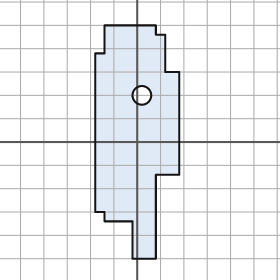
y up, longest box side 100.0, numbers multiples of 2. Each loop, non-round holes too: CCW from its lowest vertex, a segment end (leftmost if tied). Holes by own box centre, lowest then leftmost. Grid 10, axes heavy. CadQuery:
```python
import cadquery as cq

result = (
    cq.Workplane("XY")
    .moveTo(-2.0, -50.0)
    .lineTo(8.0, -50.0)
    .lineTo(8.0, -14.0)
    .lineTo(18.0, -14.0)
    .lineTo(18.0, 30.0)
    .lineTo(12.0, 30.0)
    .lineTo(12.0, 46.0)
    .lineTo(8.0, 46.0)
    .lineTo(8.0, 50.0)
    .lineTo(-14.0, 50.0)
    .lineTo(-14.0, 38.0)
    .lineTo(-18.0, 38.0)
    .lineTo(-18.0, -30.0)
    .lineTo(-14.0, -30.0)
    .lineTo(-14.0, -34.0)
    .lineTo(-2.0, -34.0)
    .close()
    .moveTo(2.0, 20.0)
    .circle(4.0)
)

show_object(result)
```